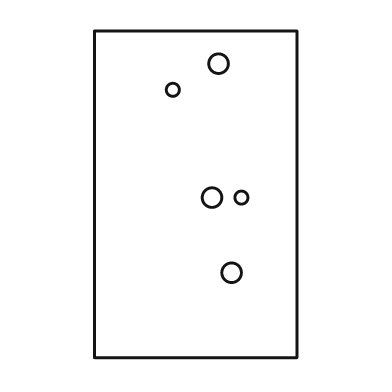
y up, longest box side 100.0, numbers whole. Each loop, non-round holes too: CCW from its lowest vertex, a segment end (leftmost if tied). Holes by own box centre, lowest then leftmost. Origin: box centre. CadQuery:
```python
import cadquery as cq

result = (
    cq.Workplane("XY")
    .moveTo(-31.0, -50.0)
    .lineTo(31.0, -50.0)
    .lineTo(31.0, 50.0)
    .lineTo(-31.0, 50.0)
    .close()
    .moveTo(11.0, -24.0)
    .circle(3.0)
    .moveTo(5.0, -1.0)
    .circle(3.0)
    .moveTo(14.0, -1.0)
    .circle(2.0)
    .moveTo(-7.0, 32.0)
    .circle(2.0)
    .moveTo(7.0, 40.0)
    .circle(3.0)
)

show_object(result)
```